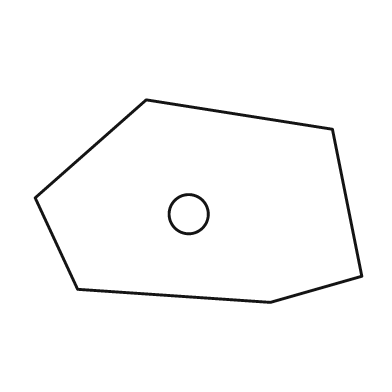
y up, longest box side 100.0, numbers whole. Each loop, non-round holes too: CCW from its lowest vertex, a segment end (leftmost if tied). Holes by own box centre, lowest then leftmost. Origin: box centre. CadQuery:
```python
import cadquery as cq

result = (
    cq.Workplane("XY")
    .moveTo(22.0, -31.0)
    .lineTo(50.0, -23.0)
    .lineTo(41.0, 22.0)
    .lineTo(-16.0, 31.0)
    .lineTo(-50.0, 1.0)
    .lineTo(-37.0, -27.0)
    .close()
    .moveTo(-3.0, -4.0)
    .circle(6.0)
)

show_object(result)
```